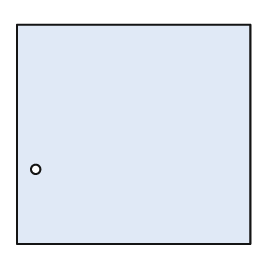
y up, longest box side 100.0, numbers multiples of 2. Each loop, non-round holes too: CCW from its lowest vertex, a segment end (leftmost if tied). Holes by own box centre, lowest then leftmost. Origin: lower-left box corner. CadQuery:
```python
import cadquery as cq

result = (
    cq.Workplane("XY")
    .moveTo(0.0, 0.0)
    .lineTo(100.0, 0.0)
    .lineTo(100.0, 94.0)
    .lineTo(0.0, 94.0)
    .close()
    .moveTo(8.0, 32.0)
    .circle(2.0)
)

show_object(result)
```